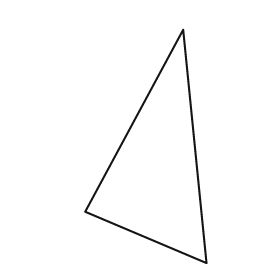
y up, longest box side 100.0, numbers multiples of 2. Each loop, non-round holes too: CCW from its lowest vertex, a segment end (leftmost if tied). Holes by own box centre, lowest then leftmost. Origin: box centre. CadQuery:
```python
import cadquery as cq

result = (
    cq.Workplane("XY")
    .moveTo(26.0, -50.0)
    .lineTo(16.0, 50.0)
    .lineTo(-26.0, -28.0)
    .close()
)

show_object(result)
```